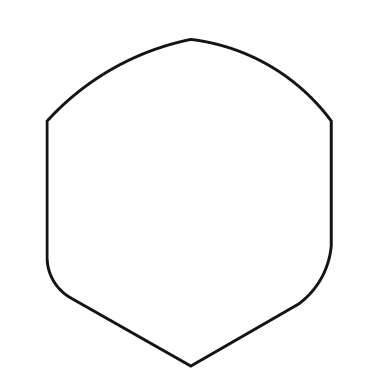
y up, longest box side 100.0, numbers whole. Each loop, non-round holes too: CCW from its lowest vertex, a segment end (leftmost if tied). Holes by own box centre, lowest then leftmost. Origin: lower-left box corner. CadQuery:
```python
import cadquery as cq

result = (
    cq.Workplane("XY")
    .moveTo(44.0, 0.0)
    .lineTo(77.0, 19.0)
    .threePointArc((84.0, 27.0), (87.0, 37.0))
    .lineTo(87.0, 75.0)
    .threePointArc((68.0, 92.0), (44.0, 100.0))
    .threePointArc((20.0, 91.0), (0.0, 75.0))
    .lineTo(0.0, 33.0)
    .threePointArc((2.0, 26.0), (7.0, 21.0))
    .close()
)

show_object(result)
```